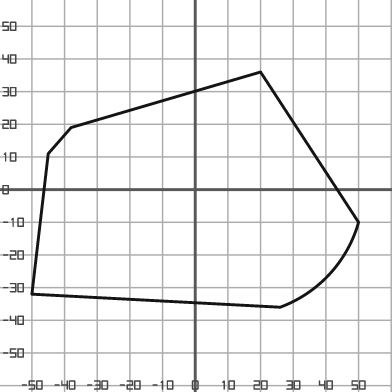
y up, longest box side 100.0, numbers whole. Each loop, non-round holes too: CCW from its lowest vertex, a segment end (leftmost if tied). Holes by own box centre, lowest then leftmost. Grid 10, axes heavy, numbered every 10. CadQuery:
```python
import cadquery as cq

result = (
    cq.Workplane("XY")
    .moveTo(26.0, -36.0)
    .threePointArc((41.0, -26.0), (50.0, -10.0))
    .lineTo(20.0, 36.0)
    .lineTo(-38.0, 19.0)
    .lineTo(-45.0, 11.0)
    .lineTo(-50.0, -32.0)
    .close()
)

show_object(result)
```